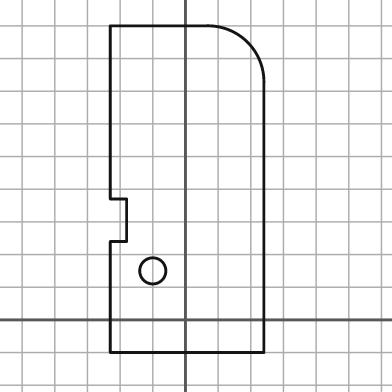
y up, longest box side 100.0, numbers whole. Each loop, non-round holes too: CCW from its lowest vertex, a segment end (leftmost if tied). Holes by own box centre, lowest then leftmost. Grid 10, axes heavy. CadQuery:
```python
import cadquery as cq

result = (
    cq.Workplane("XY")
    .moveTo(-23.0, -10.0)
    .lineTo(24.0, -10.0)
    .lineTo(24.0, 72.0)
    .threePointArc((19.0, 85.0), (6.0, 90.0))
    .lineTo(-23.0, 90.0)
    .lineTo(-23.0, 37.0)
    .lineTo(-18.0, 37.0)
    .lineTo(-18.0, 24.0)
    .lineTo(-23.0, 24.0)
    .close()
    .moveTo(-10.0, 15.0)
    .circle(4.0)
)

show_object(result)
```